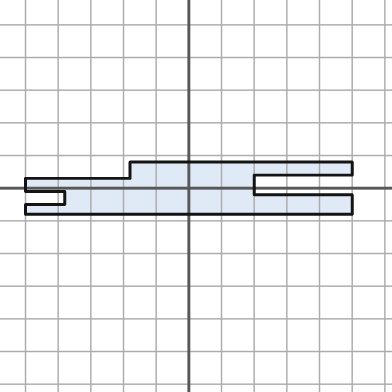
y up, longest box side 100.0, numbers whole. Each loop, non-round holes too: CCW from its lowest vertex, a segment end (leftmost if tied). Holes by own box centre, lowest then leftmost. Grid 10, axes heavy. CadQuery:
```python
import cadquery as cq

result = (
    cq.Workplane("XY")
    .moveTo(-50.0, -8.0)
    .lineTo(50.0, -8.0)
    .lineTo(50.0, -2.0)
    .lineTo(20.0, -2.0)
    .lineTo(20.0, 4.0)
    .lineTo(50.0, 4.0)
    .lineTo(50.0, 8.0)
    .lineTo(-18.0, 8.0)
    .lineTo(-18.0, 3.0)
    .lineTo(-50.0, 3.0)
    .lineTo(-50.0, -1.0)
    .lineTo(-38.0, -1.0)
    .lineTo(-38.0, -5.0)
    .lineTo(-50.0, -5.0)
    .close()
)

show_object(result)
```